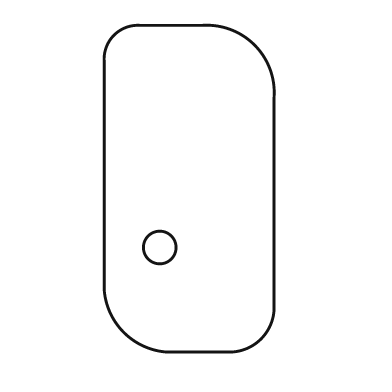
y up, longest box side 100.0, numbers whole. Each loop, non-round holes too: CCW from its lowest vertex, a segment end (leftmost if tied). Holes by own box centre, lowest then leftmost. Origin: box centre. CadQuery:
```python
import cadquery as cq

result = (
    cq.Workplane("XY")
    .moveTo(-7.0, -50.0)
    .lineTo(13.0, -50.0)
    .threePointArc((22.0, -46.0), (26.0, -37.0))
    .lineTo(26.0, 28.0)
    .threePointArc((20.0, 44.0), (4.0, 50.0))
    .lineTo(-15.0, 50.0)
    .threePointArc((-23.0, 47.0), (-26.0, 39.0))
    .lineTo(-26.0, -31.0)
    .threePointArc((-20.0, -44.0), (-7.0, -50.0))
    .close()
    .moveTo(-9.0, -18.0)
    .circle(5.0)
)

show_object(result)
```